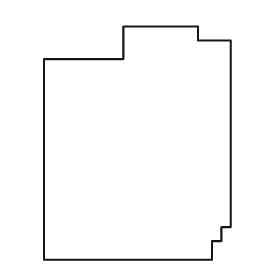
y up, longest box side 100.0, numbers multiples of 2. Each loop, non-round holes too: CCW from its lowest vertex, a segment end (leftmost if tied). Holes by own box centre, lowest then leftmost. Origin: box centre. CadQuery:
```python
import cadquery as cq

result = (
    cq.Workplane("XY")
    .moveTo(-40.0, -50.0)
    .lineTo(32.0, -50.0)
    .lineTo(32.0, -42.0)
    .lineTo(36.0, -42.0)
    .lineTo(36.0, -36.0)
    .lineTo(40.0, -36.0)
    .lineTo(40.0, 44.0)
    .lineTo(26.0, 44.0)
    .lineTo(26.0, 50.0)
    .lineTo(-6.0, 50.0)
    .lineTo(-6.0, 36.0)
    .lineTo(-40.0, 36.0)
    .close()
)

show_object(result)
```